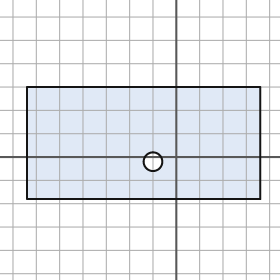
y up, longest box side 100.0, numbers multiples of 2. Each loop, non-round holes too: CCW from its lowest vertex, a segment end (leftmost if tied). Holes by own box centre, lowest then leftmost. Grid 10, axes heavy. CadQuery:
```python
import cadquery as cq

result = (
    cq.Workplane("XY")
    .moveTo(-64.0, -18.0)
    .lineTo(36.0, -18.0)
    .lineTo(36.0, 30.0)
    .lineTo(-64.0, 30.0)
    .close()
    .moveTo(-10.0, -2.0)
    .circle(4.0)
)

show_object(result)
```